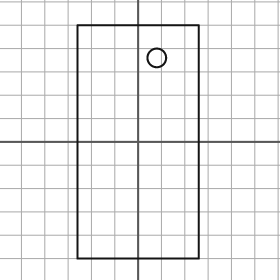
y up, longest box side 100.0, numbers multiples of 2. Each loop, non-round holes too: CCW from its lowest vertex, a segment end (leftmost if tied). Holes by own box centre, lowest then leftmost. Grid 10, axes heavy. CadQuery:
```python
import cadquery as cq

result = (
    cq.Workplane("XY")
    .moveTo(-26.0, -50.0)
    .lineTo(26.0, -50.0)
    .lineTo(26.0, 50.0)
    .lineTo(-26.0, 50.0)
    .close()
    .moveTo(8.0, 36.0)
    .circle(4.0)
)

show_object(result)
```